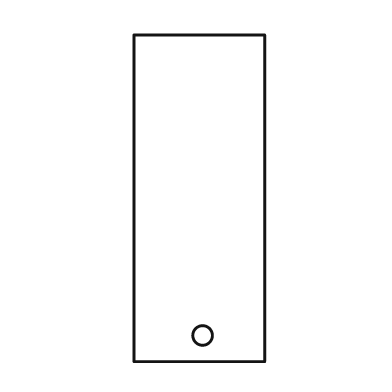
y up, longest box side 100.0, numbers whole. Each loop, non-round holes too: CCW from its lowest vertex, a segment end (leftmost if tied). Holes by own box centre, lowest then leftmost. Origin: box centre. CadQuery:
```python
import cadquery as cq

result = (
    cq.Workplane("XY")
    .moveTo(-20.0, -50.0)
    .lineTo(20.0, -50.0)
    .lineTo(20.0, 50.0)
    .lineTo(-20.0, 50.0)
    .close()
    .moveTo(1.0, -42.0)
    .circle(3.0)
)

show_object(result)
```